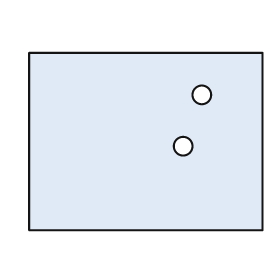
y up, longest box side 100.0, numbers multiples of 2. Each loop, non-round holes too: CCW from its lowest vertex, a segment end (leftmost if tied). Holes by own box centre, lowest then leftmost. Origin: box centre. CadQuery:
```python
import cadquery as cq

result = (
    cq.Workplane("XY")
    .moveTo(-50.0, -38.0)
    .lineTo(50.0, -38.0)
    .lineTo(50.0, 38.0)
    .lineTo(-50.0, 38.0)
    .close()
    .moveTo(16.0, -2.0)
    .circle(4.0)
    .moveTo(24.0, 20.0)
    .circle(4.0)
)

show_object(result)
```